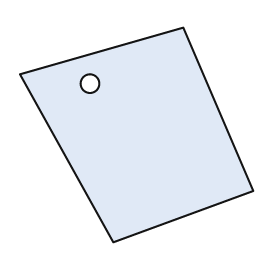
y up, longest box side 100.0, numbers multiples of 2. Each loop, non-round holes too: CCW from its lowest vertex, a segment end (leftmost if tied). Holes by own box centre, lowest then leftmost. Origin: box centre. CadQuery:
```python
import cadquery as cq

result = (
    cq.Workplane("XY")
    .moveTo(-10.0, -46.0)
    .lineTo(50.0, -24.0)
    .lineTo(20.0, 46.0)
    .lineTo(-50.0, 26.0)
    .close()
    .moveTo(-20.0, 22.0)
    .circle(4.0)
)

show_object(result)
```